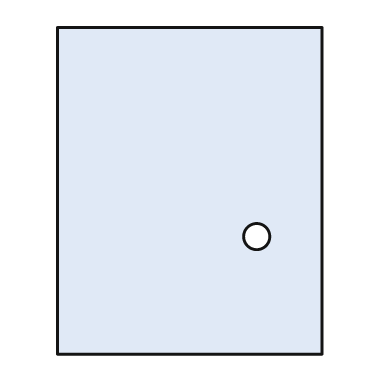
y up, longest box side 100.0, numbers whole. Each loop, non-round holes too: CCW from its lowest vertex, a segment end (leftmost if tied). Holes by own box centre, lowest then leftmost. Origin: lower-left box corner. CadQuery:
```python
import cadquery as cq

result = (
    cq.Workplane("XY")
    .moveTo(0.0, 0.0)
    .lineTo(81.0, 0.0)
    .lineTo(81.0, 100.0)
    .lineTo(0.0, 100.0)
    .close()
    .moveTo(61.0, 36.0)
    .circle(4.0)
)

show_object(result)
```